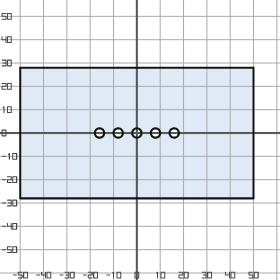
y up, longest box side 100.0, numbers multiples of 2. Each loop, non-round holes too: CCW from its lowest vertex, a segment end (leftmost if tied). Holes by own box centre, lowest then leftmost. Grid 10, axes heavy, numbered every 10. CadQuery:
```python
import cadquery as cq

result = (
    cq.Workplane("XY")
    .moveTo(-50.0, -28.0)
    .lineTo(50.0, -28.0)
    .lineTo(50.0, 28.0)
    .lineTo(-50.0, 28.0)
    .close()
    .moveTo(-16.0, 0.0)
    .circle(2.0)
    .moveTo(-8.0, 0.0)
    .circle(2.0)
    .moveTo(0.0, 0.0)
    .circle(2.0)
    .moveTo(8.0, 0.0)
    .circle(2.0)
    .moveTo(16.0, 0.0)
    .circle(2.0)
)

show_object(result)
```